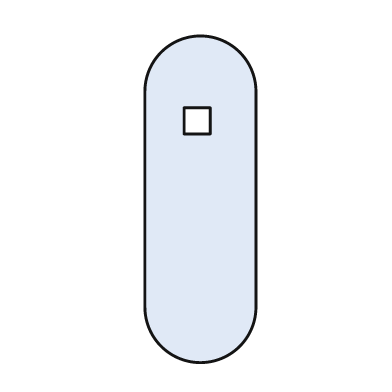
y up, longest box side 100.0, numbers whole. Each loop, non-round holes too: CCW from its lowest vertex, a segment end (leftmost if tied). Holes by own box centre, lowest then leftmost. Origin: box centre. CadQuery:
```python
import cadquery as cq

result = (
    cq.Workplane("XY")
    .moveTo(-17.0, -33.0)
    .threePointArc((0.0, -50.0), (17.0, -33.0))
    .lineTo(17.0, 33.0)
    .threePointArc((0.0, 50.0), (-17.0, 33.0))
    .close()
    .moveTo(-5.0, 20.0)
    .lineTo(3.0, 20.0)
    .lineTo(3.0, 28.0)
    .lineTo(-5.0, 28.0)
    .close()
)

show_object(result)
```